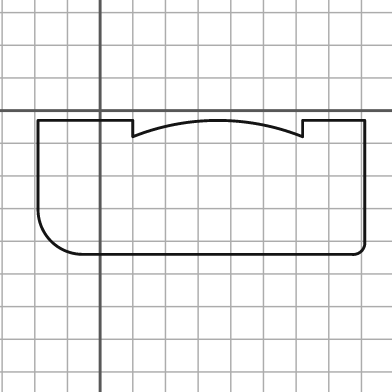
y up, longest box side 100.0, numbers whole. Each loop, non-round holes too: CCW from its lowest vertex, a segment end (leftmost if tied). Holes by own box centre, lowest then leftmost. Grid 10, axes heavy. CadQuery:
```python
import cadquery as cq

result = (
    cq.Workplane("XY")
    .moveTo(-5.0, -44.0)
    .lineTo(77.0, -44.0)
    .threePointArc((80.0, -43.0), (81.0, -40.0))
    .lineTo(81.0, -3.0)
    .lineTo(62.0, -3.0)
    .lineTo(62.0, -8.0)
    .threePointArc((36.0, -3.0), (10.0, -8.0))
    .lineTo(10.0, -3.0)
    .lineTo(-19.0, -3.0)
    .lineTo(-19.0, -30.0)
    .threePointArc((-15.0, -40.0), (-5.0, -44.0))
    .close()
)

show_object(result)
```